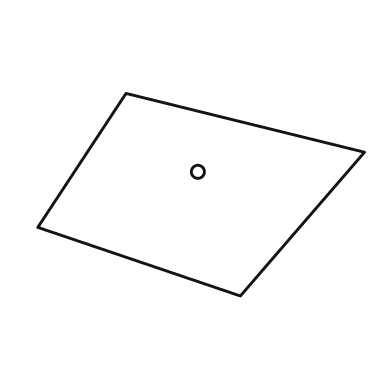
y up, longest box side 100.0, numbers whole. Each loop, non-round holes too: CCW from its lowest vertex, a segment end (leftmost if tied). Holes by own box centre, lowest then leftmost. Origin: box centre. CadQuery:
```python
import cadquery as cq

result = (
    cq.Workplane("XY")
    .moveTo(12.0, -31.0)
    .lineTo(50.0, 13.0)
    .lineTo(-23.0, 31.0)
    .lineTo(-50.0, -10.0)
    .close()
    .moveTo(-1.0, 7.0)
    .circle(2.0)
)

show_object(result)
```